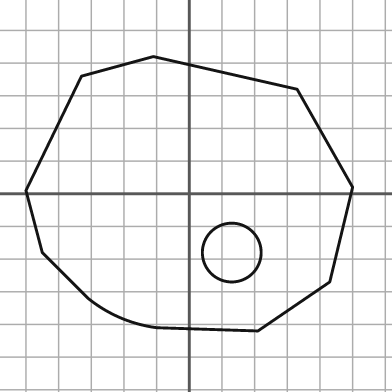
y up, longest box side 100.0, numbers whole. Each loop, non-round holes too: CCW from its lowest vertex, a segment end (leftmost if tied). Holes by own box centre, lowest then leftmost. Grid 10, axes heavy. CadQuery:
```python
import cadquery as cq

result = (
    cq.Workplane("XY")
    .moveTo(21.0, -42.0)
    .lineTo(43.0, -27.0)
    .lineTo(50.0, 2.0)
    .lineTo(33.0, 32.0)
    .lineTo(-11.0, 42.0)
    .lineTo(-33.0, 36.0)
    .lineTo(-50.0, 1.0)
    .lineTo(-45.0, -18.0)
    .lineTo(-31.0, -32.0)
    .threePointArc((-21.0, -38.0), (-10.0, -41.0))
    .close()
    .moveTo(13.0, -18.0)
    .circle(9.0)
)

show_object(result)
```